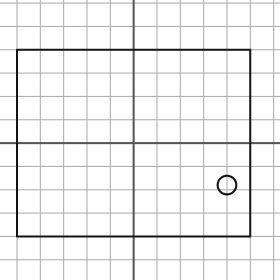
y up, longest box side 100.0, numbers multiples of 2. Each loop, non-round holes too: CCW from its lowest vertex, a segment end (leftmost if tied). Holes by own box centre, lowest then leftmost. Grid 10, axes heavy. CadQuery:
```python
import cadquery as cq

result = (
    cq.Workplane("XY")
    .moveTo(-50.0, -40.0)
    .lineTo(50.0, -40.0)
    .lineTo(50.0, 40.0)
    .lineTo(-50.0, 40.0)
    .close()
    .moveTo(40.0, -18.0)
    .circle(4.0)
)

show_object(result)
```